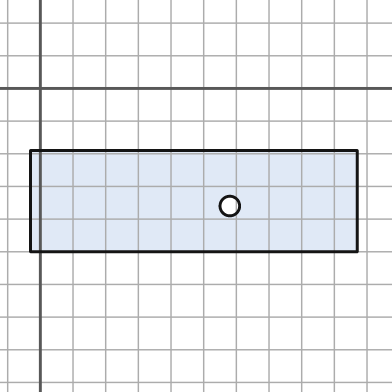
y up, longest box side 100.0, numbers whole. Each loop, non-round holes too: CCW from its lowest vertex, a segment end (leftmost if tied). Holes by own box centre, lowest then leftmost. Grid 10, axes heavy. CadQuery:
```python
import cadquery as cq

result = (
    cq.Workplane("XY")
    .moveTo(-3.0, -50.0)
    .lineTo(97.0, -50.0)
    .lineTo(97.0, -19.0)
    .lineTo(-3.0, -19.0)
    .close()
    .moveTo(58.0, -36.0)
    .circle(3.0)
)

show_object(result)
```